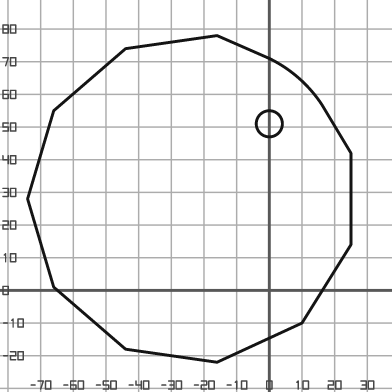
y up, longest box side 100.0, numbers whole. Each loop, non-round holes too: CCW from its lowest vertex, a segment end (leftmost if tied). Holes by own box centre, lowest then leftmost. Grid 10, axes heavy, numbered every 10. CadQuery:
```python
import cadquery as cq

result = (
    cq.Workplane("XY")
    .moveTo(-16.0, -22.0)
    .lineTo(10.0, -10.0)
    .lineTo(25.0, 14.0)
    .lineTo(25.0, 42.0)
    .lineTo(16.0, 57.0)
    .threePointArc((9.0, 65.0), (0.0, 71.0))
    .lineTo(-16.0, 78.0)
    .lineTo(-44.0, 74.0)
    .lineTo(-66.0, 55.0)
    .lineTo(-74.0, 28.0)
    .lineTo(-66.0, 1.0)
    .lineTo(-44.0, -18.0)
    .close()
    .moveTo(0.0, 51.0)
    .circle(4.0)
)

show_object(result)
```